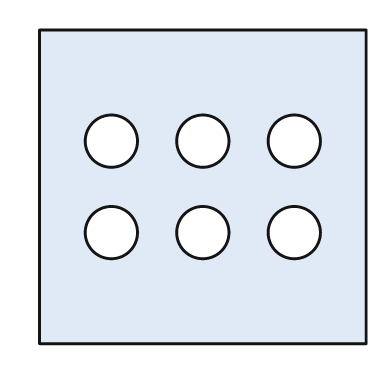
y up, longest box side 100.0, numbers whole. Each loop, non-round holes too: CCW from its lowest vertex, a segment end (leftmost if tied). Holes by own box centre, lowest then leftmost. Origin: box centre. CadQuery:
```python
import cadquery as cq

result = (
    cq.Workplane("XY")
    .moveTo(-50.0, -48.0)
    .lineTo(50.0, -48.0)
    .lineTo(50.0, 48.0)
    .lineTo(-50.0, 48.0)
    .close()
    .moveTo(-28.0, -14.0)
    .circle(8.0)
    .moveTo(0.0, -14.0)
    .circle(8.0)
    .moveTo(28.0, -14.0)
    .circle(8.0)
    .moveTo(-28.0, 14.0)
    .circle(8.0)
    .moveTo(0.0, 14.0)
    .circle(8.0)
    .moveTo(28.0, 14.0)
    .circle(8.0)
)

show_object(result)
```